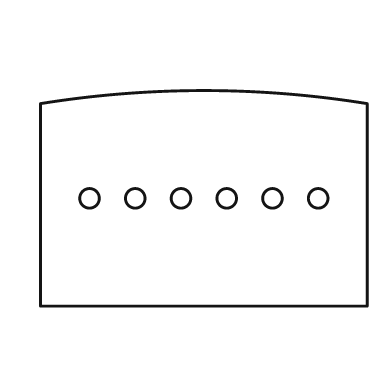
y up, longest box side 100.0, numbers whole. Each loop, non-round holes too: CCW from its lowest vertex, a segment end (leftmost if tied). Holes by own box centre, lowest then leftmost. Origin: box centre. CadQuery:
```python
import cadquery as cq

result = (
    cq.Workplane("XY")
    .moveTo(-50.0, -33.0)
    .lineTo(50.0, -33.0)
    .lineTo(50.0, 29.0)
    .threePointArc((0.0, 33.0), (-50.0, 29.0))
    .close()
    .moveTo(-35.0, 0.0)
    .circle(3.0)
    .moveTo(-21.0, 0.0)
    .circle(3.0)
    .moveTo(-7.0, 0.0)
    .circle(3.0)
    .moveTo(7.0, 0.0)
    .circle(3.0)
    .moveTo(21.0, 0.0)
    .circle(3.0)
    .moveTo(35.0, 0.0)
    .circle(3.0)
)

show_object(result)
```